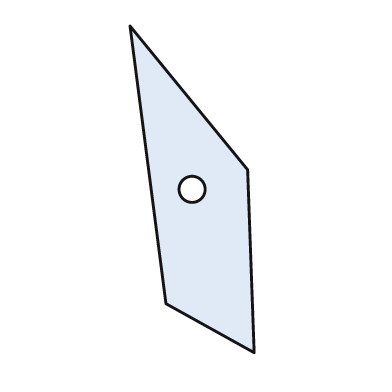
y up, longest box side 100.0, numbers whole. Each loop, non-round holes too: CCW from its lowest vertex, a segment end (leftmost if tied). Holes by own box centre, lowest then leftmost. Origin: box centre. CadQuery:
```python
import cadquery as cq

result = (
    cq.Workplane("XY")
    .moveTo(19.0, -50.0)
    .lineTo(17.0, 6.0)
    .lineTo(-19.0, 50.0)
    .lineTo(-8.0, -35.0)
    .close()
    .moveTo(0.0, 0.0)
    .circle(4.0)
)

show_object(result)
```